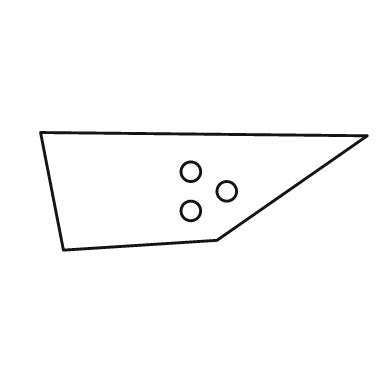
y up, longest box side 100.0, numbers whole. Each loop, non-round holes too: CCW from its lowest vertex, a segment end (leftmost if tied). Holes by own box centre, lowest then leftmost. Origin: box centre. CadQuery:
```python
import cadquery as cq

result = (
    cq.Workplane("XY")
    .moveTo(-43.0, -18.0)
    .lineTo(4.0, -15.0)
    .lineTo(50.0, 17.0)
    .lineTo(-50.0, 18.0)
    .close()
    .moveTo(-4.0, -6.0)
    .circle(3.0)
    .moveTo(7.0, 0.0)
    .circle(3.0)
    .moveTo(-4.0, 6.0)
    .circle(3.0)
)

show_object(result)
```